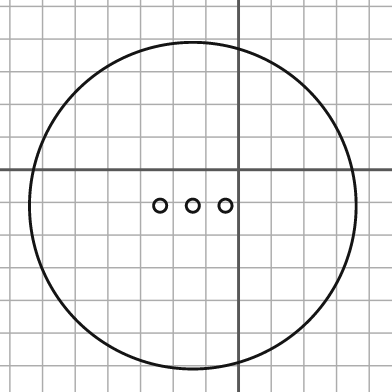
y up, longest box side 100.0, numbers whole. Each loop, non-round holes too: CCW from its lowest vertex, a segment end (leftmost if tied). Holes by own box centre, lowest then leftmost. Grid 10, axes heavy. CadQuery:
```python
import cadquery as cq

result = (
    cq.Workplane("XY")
    .moveTo(-14.0, -11.0)
    .circle(50.0)
    .moveTo(-24.0, -11.0)
    .circle(2.0)
    .moveTo(-14.0, -11.0)
    .circle(2.0)
    .moveTo(-4.0, -11.0)
    .circle(2.0)
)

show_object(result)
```